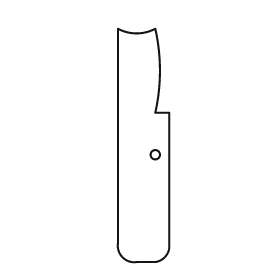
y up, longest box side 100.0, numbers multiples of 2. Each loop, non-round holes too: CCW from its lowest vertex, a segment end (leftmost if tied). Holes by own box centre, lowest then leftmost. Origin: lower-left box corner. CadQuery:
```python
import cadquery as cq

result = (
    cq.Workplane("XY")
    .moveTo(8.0, 0.0)
    .lineTo(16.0, 0.0)
    .threePointArc((20.0, 2.0), (22.0, 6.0))
    .lineTo(22.0, 64.0)
    .lineTo(16.0, 64.0)
    .threePointArc((18.0, 82.0), (16.0, 100.0))
    .threePointArc((8.0, 98.0), (0.0, 100.0))
    .lineTo(0.0, 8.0)
    .threePointArc((2.0, 2.0), (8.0, 0.0))
    .close()
    .moveTo(16.0, 46.0)
    .circle(2.0)
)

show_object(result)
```